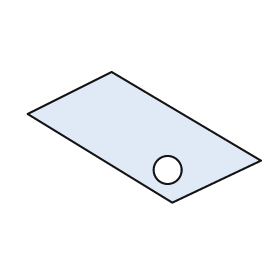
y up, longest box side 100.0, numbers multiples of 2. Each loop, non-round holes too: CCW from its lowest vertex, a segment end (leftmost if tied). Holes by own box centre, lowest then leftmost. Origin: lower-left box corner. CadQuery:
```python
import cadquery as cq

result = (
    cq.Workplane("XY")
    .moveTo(62.0, 0.0)
    .lineTo(100.0, 18.0)
    .lineTo(36.0, 56.0)
    .lineTo(0.0, 38.0)
    .close()
    .moveTo(60.0, 14.0)
    .circle(6.0)
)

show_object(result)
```